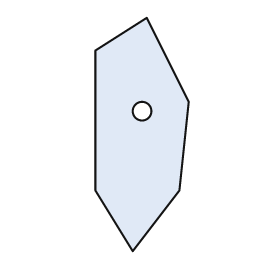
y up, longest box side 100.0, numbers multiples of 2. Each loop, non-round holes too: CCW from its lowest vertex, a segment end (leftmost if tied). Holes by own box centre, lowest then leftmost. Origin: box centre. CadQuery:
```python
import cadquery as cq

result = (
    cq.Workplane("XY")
    .moveTo(-4.0, -50.0)
    .lineTo(16.0, -24.0)
    .lineTo(20.0, 14.0)
    .lineTo(2.0, 50.0)
    .lineTo(-20.0, 36.0)
    .lineTo(-20.0, -24.0)
    .close()
    .moveTo(0.0, 10.0)
    .circle(4.0)
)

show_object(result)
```